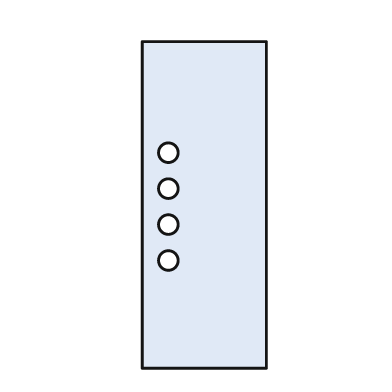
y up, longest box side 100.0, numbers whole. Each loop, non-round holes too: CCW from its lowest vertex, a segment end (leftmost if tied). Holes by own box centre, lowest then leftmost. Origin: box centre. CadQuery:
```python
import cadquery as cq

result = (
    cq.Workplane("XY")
    .moveTo(-19.0, -50.0)
    .lineTo(19.0, -50.0)
    .lineTo(19.0, 50.0)
    .lineTo(-19.0, 50.0)
    .close()
    .moveTo(-11.0, -17.0)
    .circle(3.0)
    .moveTo(-11.0, -6.0)
    .circle(3.0)
    .moveTo(-11.0, 5.0)
    .circle(3.0)
    .moveTo(-11.0, 16.0)
    .circle(3.0)
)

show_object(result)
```